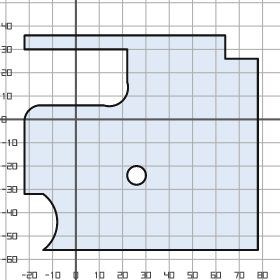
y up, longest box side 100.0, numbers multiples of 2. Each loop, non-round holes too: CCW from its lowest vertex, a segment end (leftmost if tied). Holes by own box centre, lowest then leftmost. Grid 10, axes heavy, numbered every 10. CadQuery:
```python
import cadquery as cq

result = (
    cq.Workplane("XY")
    .moveTo(-14.0, -56.0)
    .lineTo(78.0, -56.0)
    .lineTo(78.0, 26.0)
    .lineTo(64.0, 26.0)
    .lineTo(64.0, 36.0)
    .lineTo(-22.0, 36.0)
    .lineTo(-22.0, 30.0)
    .lineTo(22.0, 30.0)
    .lineTo(22.0, 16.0)
    .threePointArc((20.0, 8.0), (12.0, 6.0))
    .lineTo(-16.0, 6.0)
    .threePointArc((-20.0, 4.0), (-22.0, 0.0))
    .lineTo(-22.0, -32.0)
    .lineTo(-14.0, -32.0)
    .threePointArc((-8.0, -44.0), (-14.0, -56.0))
    .close()
    .moveTo(26.0, -24.0)
    .circle(4.0)
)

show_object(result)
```